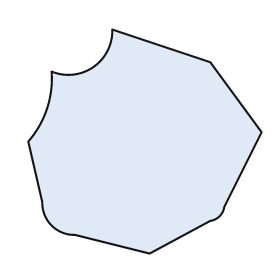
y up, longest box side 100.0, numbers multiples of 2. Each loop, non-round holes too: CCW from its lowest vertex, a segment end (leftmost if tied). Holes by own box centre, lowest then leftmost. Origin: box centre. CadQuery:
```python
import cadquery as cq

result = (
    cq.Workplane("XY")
    .moveTo(2.0, -48.0)
    .lineTo(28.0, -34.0)
    .threePointArc((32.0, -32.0), (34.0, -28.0))
    .lineTo(50.0, 4.0)
    .lineTo(28.0, 34.0)
    .lineTo(-14.0, 48.0)
    .threePointArc((-22.0, 32.0), (-40.0, 30.0))
    .threePointArc((-42.0, 14.0), (-50.0, 0.0))
    .lineTo(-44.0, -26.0)
    .threePointArc((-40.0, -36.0), (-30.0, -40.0))
    .close()
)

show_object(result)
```